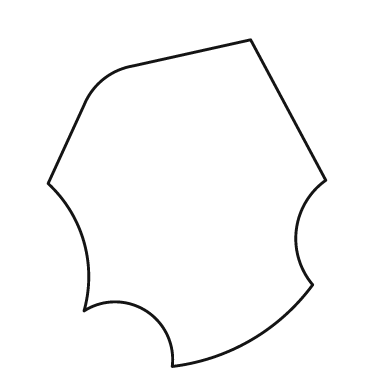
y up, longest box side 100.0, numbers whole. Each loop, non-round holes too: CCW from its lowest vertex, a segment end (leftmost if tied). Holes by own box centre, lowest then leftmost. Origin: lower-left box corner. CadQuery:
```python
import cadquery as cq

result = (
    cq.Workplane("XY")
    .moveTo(38.0, 0.0)
    .threePointArc((62.0, 8.0), (81.0, 25.0))
    .threePointArc((76.0, 42.0), (85.0, 57.0))
    .lineTo(62.0, 100.0)
    .lineTo(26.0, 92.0)
    .threePointArc((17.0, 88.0), (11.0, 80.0))
    .lineTo(0.0, 56.0)
    .threePointArc((11.0, 38.0), (11.0, 17.0))
    .threePointArc((30.0, 17.0), (38.0, 0.0))
    .close()
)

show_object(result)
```